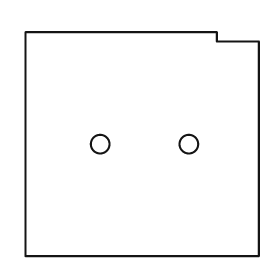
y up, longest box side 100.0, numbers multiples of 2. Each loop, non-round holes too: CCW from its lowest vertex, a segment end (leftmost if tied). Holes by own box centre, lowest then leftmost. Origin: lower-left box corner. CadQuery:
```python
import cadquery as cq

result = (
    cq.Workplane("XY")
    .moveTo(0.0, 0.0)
    .lineTo(100.0, 0.0)
    .lineTo(100.0, 92.0)
    .lineTo(82.0, 92.0)
    .lineTo(82.0, 96.0)
    .lineTo(0.0, 96.0)
    .close()
    .moveTo(32.0, 48.0)
    .circle(4.0)
    .moveTo(70.0, 48.0)
    .circle(4.0)
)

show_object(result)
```